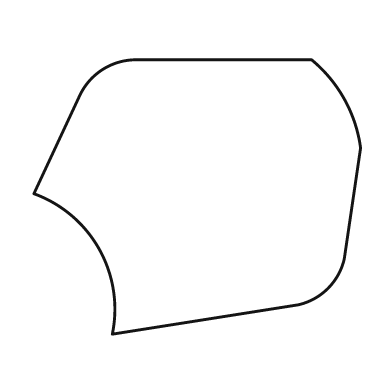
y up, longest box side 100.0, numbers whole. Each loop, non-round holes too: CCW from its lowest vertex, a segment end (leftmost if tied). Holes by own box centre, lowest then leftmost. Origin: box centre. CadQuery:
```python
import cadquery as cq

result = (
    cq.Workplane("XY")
    .moveTo(-26.0, -42.0)
    .lineTo(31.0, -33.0)
    .threePointArc((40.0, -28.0), (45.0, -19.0))
    .lineTo(50.0, 15.0)
    .threePointArc((45.0, 30.0), (35.0, 42.0))
    .lineTo(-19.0, 42.0)
    .threePointArc((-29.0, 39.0), (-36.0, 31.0))
    .lineTo(-50.0, 1.0)
    .threePointArc((-30.0, -16.0), (-26.0, -42.0))
    .close()
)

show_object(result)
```